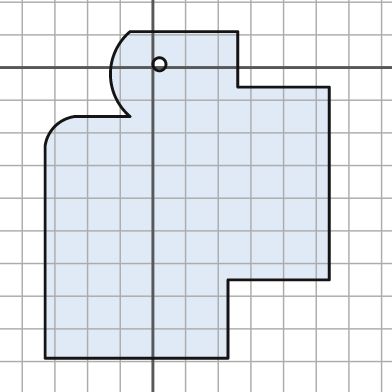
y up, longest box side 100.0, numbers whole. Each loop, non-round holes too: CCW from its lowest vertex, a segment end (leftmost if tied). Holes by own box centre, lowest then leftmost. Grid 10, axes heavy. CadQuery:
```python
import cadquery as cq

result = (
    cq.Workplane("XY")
    .moveTo(-33.0, -89.0)
    .lineTo(23.0, -89.0)
    .lineTo(23.0, -65.0)
    .lineTo(54.0, -65.0)
    .lineTo(54.0, -6.0)
    .lineTo(26.0, -6.0)
    .lineTo(26.0, 11.0)
    .lineTo(-7.0, 11.0)
    .threePointArc((-13.0, -2.0), (-7.0, -15.0))
    .lineTo(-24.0, -15.0)
    .threePointArc((-30.0, -18.0), (-33.0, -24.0))
    .close()
    .moveTo(2.0, 1.0)
    .circle(2.0)
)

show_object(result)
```